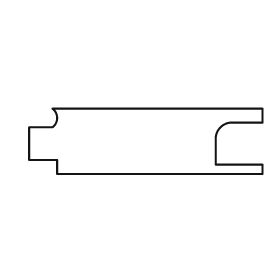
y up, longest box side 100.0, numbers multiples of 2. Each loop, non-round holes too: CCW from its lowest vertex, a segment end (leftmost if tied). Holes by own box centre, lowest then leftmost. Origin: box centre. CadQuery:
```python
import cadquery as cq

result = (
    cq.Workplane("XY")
    .moveTo(-38.0, -14.0)
    .lineTo(50.0, -14.0)
    .lineTo(50.0, -10.0)
    .lineTo(30.0, -10.0)
    .lineTo(30.0, 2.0)
    .threePointArc((32.0, 6.0), (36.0, 8.0))
    .lineTo(50.0, 8.0)
    .lineTo(50.0, 14.0)
    .lineTo(-40.0, 14.0)
    .threePointArc((-38.0, 10.0), (-40.0, 6.0))
    .lineTo(-50.0, 6.0)
    .lineTo(-50.0, -8.0)
    .lineTo(-38.0, -8.0)
    .close()
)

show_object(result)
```